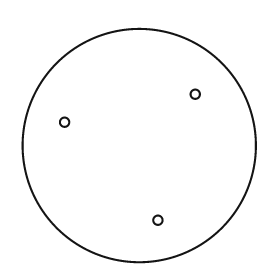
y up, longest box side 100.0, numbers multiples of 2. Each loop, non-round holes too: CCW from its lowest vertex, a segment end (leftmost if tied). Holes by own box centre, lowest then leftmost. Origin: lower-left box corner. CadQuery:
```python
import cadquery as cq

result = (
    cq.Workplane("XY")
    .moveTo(50.0, 50.0)
    .circle(50.0)
    .moveTo(58.0, 18.0)
    .circle(2.0)
    .moveTo(18.0, 60.0)
    .circle(2.0)
    .moveTo(74.0, 72.0)
    .circle(2.0)
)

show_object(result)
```